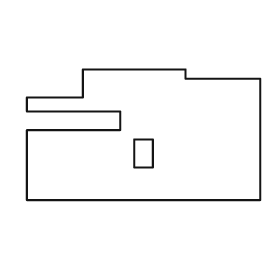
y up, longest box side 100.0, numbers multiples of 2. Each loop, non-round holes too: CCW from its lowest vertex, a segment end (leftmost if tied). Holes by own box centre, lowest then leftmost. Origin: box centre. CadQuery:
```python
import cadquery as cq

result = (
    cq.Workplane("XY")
    .moveTo(-50.0, -28.0)
    .lineTo(50.0, -28.0)
    .lineTo(50.0, 24.0)
    .lineTo(18.0, 24.0)
    .lineTo(18.0, 28.0)
    .lineTo(-26.0, 28.0)
    .lineTo(-26.0, 16.0)
    .lineTo(-50.0, 16.0)
    .lineTo(-50.0, 10.0)
    .lineTo(-10.0, 10.0)
    .lineTo(-10.0, 2.0)
    .lineTo(-50.0, 2.0)
    .close()
    .moveTo(-4.0, -14.0)
    .lineTo(4.0, -14.0)
    .lineTo(4.0, -2.0)
    .lineTo(-4.0, -2.0)
    .close()
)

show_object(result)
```